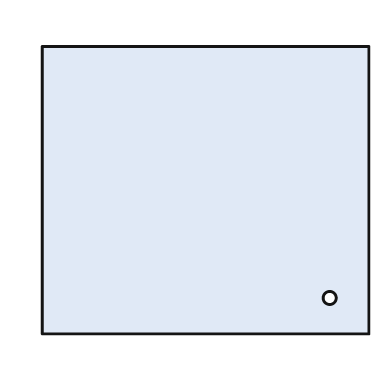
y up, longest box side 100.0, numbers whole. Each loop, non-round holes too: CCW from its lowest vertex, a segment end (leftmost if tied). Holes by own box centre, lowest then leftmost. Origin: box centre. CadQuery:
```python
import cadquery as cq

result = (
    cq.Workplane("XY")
    .moveTo(-50.0, -44.0)
    .lineTo(50.0, -44.0)
    .lineTo(50.0, 44.0)
    .lineTo(-50.0, 44.0)
    .close()
    .moveTo(38.0, -33.0)
    .circle(2.0)
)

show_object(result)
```